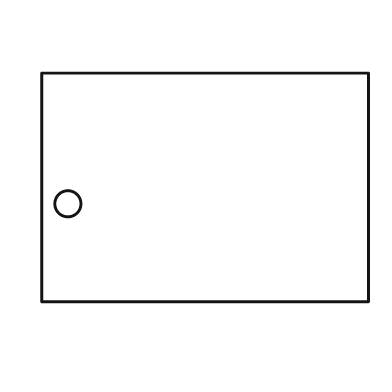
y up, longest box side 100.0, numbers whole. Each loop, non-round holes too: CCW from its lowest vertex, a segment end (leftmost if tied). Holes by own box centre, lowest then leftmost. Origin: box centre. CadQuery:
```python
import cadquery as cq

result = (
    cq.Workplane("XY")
    .moveTo(-50.0, -35.0)
    .lineTo(50.0, -35.0)
    .lineTo(50.0, 35.0)
    .lineTo(-50.0, 35.0)
    .close()
    .moveTo(-42.0, -5.0)
    .circle(4.0)
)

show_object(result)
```